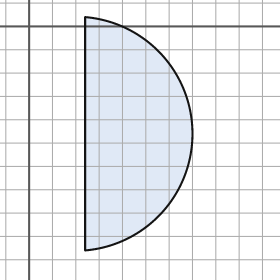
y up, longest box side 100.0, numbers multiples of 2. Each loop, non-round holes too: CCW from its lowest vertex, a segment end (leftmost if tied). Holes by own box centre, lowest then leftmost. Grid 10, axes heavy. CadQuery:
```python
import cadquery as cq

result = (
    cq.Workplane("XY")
    .moveTo(24.0, -96.0)
    .threePointArc((70.0, -46.0), (24.0, 4.0))
    .close()
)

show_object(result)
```